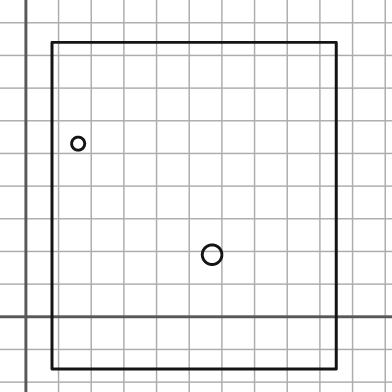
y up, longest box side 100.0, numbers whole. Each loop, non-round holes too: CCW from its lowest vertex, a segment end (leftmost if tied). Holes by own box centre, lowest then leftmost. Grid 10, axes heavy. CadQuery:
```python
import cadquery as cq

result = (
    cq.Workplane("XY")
    .moveTo(8.0, -16.0)
    .lineTo(95.0, -16.0)
    .lineTo(95.0, 84.0)
    .lineTo(8.0, 84.0)
    .close()
    .moveTo(57.0, 19.0)
    .circle(3.0)
    .moveTo(16.0, 53.0)
    .circle(2.0)
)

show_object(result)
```